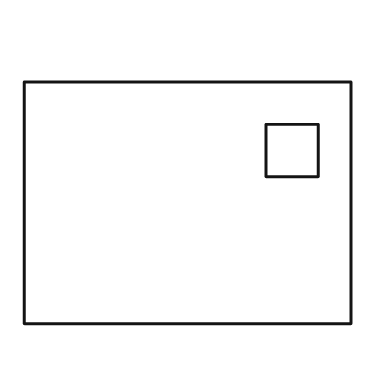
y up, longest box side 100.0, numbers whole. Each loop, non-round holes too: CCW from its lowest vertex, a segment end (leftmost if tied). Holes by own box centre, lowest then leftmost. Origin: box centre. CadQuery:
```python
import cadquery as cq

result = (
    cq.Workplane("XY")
    .moveTo(-50.0, -37.0)
    .lineTo(50.0, -37.0)
    .lineTo(50.0, 37.0)
    .lineTo(-50.0, 37.0)
    .close()
    .moveTo(24.0, 8.0)
    .lineTo(40.0, 8.0)
    .lineTo(40.0, 24.0)
    .lineTo(24.0, 24.0)
    .close()
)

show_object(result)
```